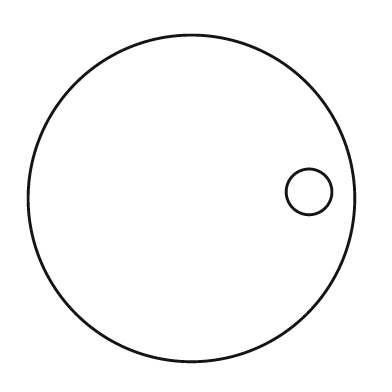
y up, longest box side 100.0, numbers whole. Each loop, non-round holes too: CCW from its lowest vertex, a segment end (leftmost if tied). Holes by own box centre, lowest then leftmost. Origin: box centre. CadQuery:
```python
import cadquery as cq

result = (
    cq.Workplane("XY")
    .moveTo(0.0, 0.0)
    .circle(50.0)
    .moveTo(36.0, 2.0)
    .circle(7.0)
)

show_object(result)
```